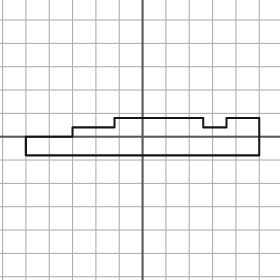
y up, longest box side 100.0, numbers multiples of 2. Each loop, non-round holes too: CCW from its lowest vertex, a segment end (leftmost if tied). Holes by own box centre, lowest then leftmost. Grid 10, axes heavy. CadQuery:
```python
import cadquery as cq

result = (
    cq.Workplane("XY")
    .moveTo(-50.0, -8.0)
    .lineTo(50.0, -8.0)
    .lineTo(50.0, 8.0)
    .lineTo(36.0, 8.0)
    .lineTo(36.0, 4.0)
    .lineTo(26.0, 4.0)
    .lineTo(26.0, 8.0)
    .lineTo(-12.0, 8.0)
    .lineTo(-12.0, 4.0)
    .lineTo(-30.0, 4.0)
    .lineTo(-30.0, 0.0)
    .lineTo(-50.0, 0.0)
    .close()
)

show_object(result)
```